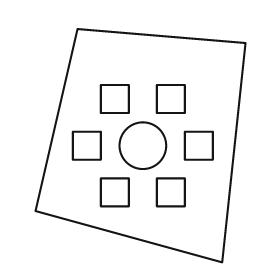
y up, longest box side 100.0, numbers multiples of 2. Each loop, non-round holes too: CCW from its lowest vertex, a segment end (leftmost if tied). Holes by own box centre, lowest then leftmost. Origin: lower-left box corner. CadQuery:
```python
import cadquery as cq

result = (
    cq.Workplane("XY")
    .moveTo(80.0, 0.0)
    .lineTo(90.0, 94.0)
    .lineTo(18.0, 100.0)
    .lineTo(0.0, 22.0)
    .close()
    .moveTo(28.0, 24.0)
    .lineTo(40.0, 24.0)
    .lineTo(40.0, 36.0)
    .lineTo(28.0, 36.0)
    .close()
    .moveTo(52.0, 24.0)
    .lineTo(64.0, 24.0)
    .lineTo(64.0, 36.0)
    .lineTo(52.0, 36.0)
    .close()
    .moveTo(16.0, 44.0)
    .lineTo(28.0, 44.0)
    .lineTo(28.0, 56.0)
    .lineTo(16.0, 56.0)
    .close()
    .moveTo(46.0, 50.0)
    .circle(10.0)
    .moveTo(64.0, 44.0)
    .lineTo(76.0, 44.0)
    .lineTo(76.0, 56.0)
    .lineTo(64.0, 56.0)
    .close()
    .moveTo(28.0, 64.0)
    .lineTo(40.0, 64.0)
    .lineTo(40.0, 76.0)
    .lineTo(28.0, 76.0)
    .close()
    .moveTo(52.0, 64.0)
    .lineTo(64.0, 64.0)
    .lineTo(64.0, 76.0)
    .lineTo(52.0, 76.0)
    .close()
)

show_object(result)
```